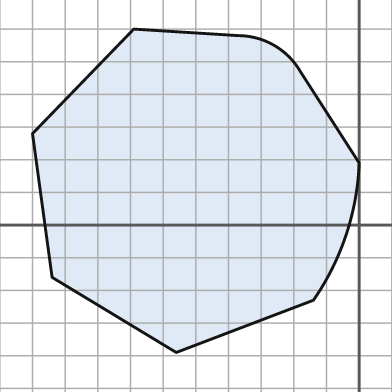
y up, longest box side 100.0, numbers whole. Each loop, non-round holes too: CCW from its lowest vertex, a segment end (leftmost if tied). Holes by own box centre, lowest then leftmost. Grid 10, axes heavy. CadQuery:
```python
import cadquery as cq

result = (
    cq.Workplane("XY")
    .moveTo(-56.0, -39.0)
    .lineTo(-14.0, -23.0)
    .threePointArc((-4.0, -3.0), (0.0, 19.0))
    .lineTo(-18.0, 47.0)
    .threePointArc((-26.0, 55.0), (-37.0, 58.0))
    .lineTo(-69.0, 60.0)
    .lineTo(-100.0, 28.0)
    .lineTo(-94.0, -16.0)
    .close()
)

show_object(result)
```